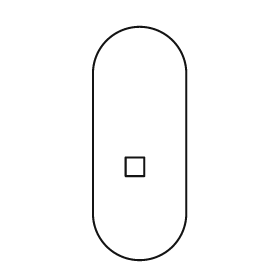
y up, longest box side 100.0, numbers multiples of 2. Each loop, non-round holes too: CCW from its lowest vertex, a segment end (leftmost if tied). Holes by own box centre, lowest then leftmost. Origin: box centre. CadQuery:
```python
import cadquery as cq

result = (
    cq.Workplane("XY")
    .moveTo(-20.0, -30.0)
    .threePointArc((0.0, -50.0), (20.0, -30.0))
    .lineTo(20.0, 30.0)
    .threePointArc((0.0, 50.0), (-20.0, 30.0))
    .close()
    .moveTo(-6.0, -14.0)
    .lineTo(2.0, -14.0)
    .lineTo(2.0, -6.0)
    .lineTo(-6.0, -6.0)
    .close()
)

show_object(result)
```